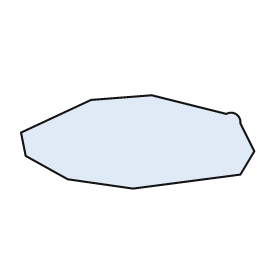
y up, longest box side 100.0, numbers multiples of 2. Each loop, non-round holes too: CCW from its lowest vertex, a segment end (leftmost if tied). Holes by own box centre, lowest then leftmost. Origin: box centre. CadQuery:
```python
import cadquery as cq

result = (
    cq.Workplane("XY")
    .moveTo(-2.0, -20.0)
    .lineTo(44.0, -14.0)
    .lineTo(50.0, -4.0)
    .lineTo(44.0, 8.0)
    .threePointArc((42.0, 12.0), (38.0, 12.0))
    .lineTo(6.0, 20.0)
    .lineTo(-20.0, 18.0)
    .lineTo(-50.0, 4.0)
    .lineTo(-48.0, -6.0)
    .lineTo(-30.0, -16.0)
    .close()
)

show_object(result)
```